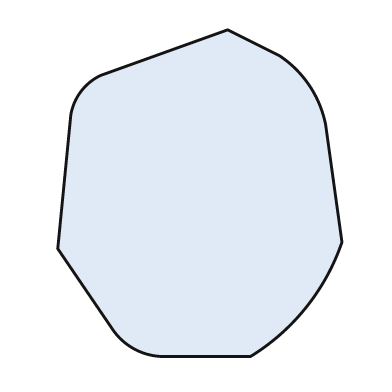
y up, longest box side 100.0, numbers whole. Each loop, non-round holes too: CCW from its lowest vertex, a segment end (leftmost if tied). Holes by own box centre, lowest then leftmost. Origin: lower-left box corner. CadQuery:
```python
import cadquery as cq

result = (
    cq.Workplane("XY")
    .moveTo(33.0, 0.0)
    .lineTo(59.0, 0.0)
    .threePointArc((76.0, 15.0), (87.0, 35.0))
    .lineTo(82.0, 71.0)
    .threePointArc((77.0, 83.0), (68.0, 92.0))
    .lineTo(52.0, 100.0)
    .lineTo(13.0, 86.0)
    .threePointArc((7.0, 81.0), (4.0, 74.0))
    .lineTo(0.0, 33.0)
    .lineTo(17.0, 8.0)
    .threePointArc((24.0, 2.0), (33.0, 0.0))
    .close()
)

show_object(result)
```